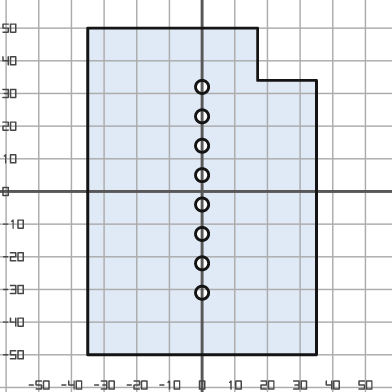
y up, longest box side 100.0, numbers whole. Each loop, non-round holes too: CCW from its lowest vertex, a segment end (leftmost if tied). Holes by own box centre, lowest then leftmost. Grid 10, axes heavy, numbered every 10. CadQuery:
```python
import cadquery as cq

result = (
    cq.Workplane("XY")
    .moveTo(-35.0, -50.0)
    .lineTo(35.0, -50.0)
    .lineTo(35.0, 34.0)
    .lineTo(17.0, 34.0)
    .lineTo(17.0, 50.0)
    .lineTo(-35.0, 50.0)
    .close()
    .moveTo(0.0, -31.0)
    .circle(2.0)
    .moveTo(0.0, -22.0)
    .circle(2.0)
    .moveTo(0.0, -13.0)
    .circle(2.0)
    .moveTo(0.0, -4.0)
    .circle(2.0)
    .moveTo(0.0, 5.0)
    .circle(2.0)
    .moveTo(0.0, 14.0)
    .circle(2.0)
    .moveTo(0.0, 23.0)
    .circle(2.0)
    .moveTo(0.0, 32.0)
    .circle(2.0)
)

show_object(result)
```